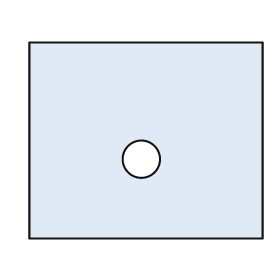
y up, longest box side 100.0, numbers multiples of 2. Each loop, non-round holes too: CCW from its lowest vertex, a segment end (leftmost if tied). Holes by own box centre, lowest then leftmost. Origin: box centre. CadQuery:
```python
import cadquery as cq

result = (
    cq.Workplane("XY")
    .moveTo(-50.0, -42.0)
    .lineTo(50.0, -42.0)
    .lineTo(50.0, 42.0)
    .lineTo(-50.0, 42.0)
    .close()
    .moveTo(-2.0, -8.0)
    .circle(8.0)
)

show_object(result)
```